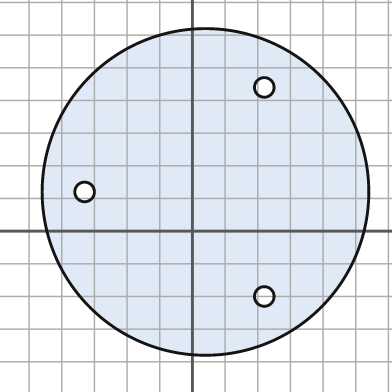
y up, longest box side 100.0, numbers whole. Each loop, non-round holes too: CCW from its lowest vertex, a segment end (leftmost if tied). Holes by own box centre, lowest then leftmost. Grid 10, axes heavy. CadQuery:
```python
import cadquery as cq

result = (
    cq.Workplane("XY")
    .moveTo(4.0, 12.0)
    .circle(50.0)
    .moveTo(22.0, -20.0)
    .circle(3.0)
    .moveTo(-33.0, 12.0)
    .circle(3.0)
    .moveTo(22.0, 44.0)
    .circle(3.0)
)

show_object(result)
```